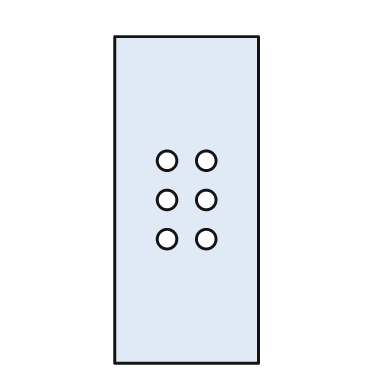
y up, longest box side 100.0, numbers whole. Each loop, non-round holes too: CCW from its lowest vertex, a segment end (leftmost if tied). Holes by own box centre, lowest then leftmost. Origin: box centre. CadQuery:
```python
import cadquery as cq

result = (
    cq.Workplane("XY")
    .moveTo(-22.0, -50.0)
    .lineTo(22.0, -50.0)
    .lineTo(22.0, 50.0)
    .lineTo(-22.0, 50.0)
    .close()
    .moveTo(-6.0, -12.0)
    .circle(3.0)
    .moveTo(6.0, -12.0)
    .circle(3.0)
    .moveTo(-6.0, 0.0)
    .circle(3.0)
    .moveTo(6.0, 0.0)
    .circle(3.0)
    .moveTo(-6.0, 12.0)
    .circle(3.0)
    .moveTo(6.0, 12.0)
    .circle(3.0)
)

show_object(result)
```